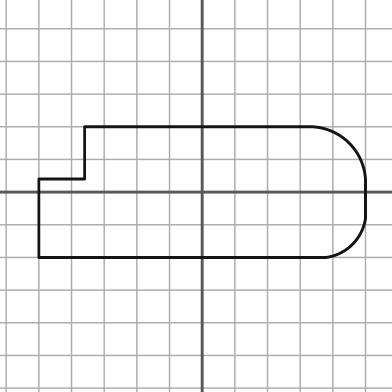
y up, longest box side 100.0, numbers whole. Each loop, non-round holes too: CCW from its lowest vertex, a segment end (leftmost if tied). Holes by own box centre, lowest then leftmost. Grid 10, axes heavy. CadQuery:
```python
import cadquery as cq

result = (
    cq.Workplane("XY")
    .moveTo(-50.0, -20.0)
    .lineTo(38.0, -20.0)
    .threePointArc((46.0, -16.0), (50.0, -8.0))
    .lineTo(50.0, 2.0)
    .threePointArc((45.0, 15.0), (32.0, 20.0))
    .lineTo(-36.0, 20.0)
    .lineTo(-36.0, 4.0)
    .lineTo(-50.0, 4.0)
    .close()
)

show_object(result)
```